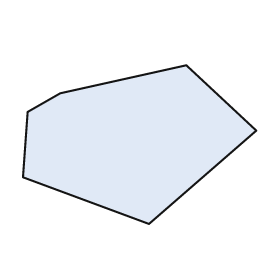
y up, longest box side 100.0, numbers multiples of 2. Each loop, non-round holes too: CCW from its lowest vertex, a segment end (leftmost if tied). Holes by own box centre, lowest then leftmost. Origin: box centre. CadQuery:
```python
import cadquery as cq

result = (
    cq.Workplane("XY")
    .moveTo(4.0, -34.0)
    .lineTo(50.0, 6.0)
    .lineTo(20.0, 34.0)
    .lineTo(-34.0, 22.0)
    .lineTo(-48.0, 14.0)
    .lineTo(-50.0, -14.0)
    .close()
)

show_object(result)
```